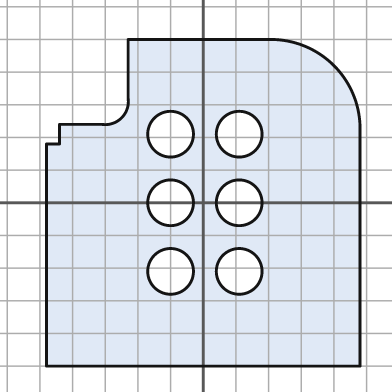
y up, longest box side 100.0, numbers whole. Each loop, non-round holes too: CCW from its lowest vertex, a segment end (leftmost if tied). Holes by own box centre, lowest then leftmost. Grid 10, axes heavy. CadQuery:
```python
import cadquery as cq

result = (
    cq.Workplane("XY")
    .moveTo(-48.0, -50.0)
    .lineTo(48.0, -50.0)
    .lineTo(48.0, 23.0)
    .threePointArc((40.0, 42.0), (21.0, 50.0))
    .lineTo(-23.0, 50.0)
    .lineTo(-23.0, 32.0)
    .threePointArc((-25.0, 26.0), (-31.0, 24.0))
    .lineTo(-44.0, 24.0)
    .lineTo(-44.0, 18.0)
    .lineTo(-48.0, 18.0)
    .close()
    .moveTo(-10.0, -21.0)
    .circle(7.0)
    .moveTo(11.0, -21.0)
    .circle(7.0)
    .moveTo(-10.0, 0.0)
    .circle(7.0)
    .moveTo(11.0, 0.0)
    .circle(7.0)
    .moveTo(-10.0, 21.0)
    .circle(7.0)
    .moveTo(11.0, 21.0)
    .circle(7.0)
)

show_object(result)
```